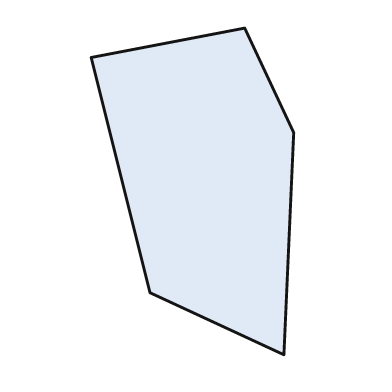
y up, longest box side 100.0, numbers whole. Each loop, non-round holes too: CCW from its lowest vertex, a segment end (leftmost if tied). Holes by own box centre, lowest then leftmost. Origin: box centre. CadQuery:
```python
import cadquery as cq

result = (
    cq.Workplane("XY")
    .moveTo(28.0, -50.0)
    .lineTo(31.0, 18.0)
    .lineTo(16.0, 50.0)
    .lineTo(-31.0, 41.0)
    .lineTo(-13.0, -31.0)
    .close()
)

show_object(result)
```